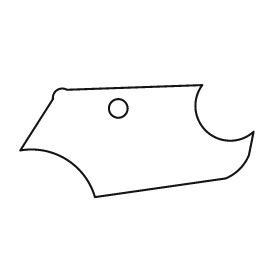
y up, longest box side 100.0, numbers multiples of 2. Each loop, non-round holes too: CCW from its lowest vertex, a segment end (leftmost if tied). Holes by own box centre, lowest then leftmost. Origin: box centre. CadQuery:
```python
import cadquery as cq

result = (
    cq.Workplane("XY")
    .moveTo(-18.0, -24.0)
    .lineTo(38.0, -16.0)
    .threePointArc((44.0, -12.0), (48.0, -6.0))
    .lineTo(50.0, 4.0)
    .threePointArc((30.0, 4.0), (28.0, 24.0))
    .lineTo(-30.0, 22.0)
    .threePointArc((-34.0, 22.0), (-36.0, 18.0))
    .lineTo(-50.0, -4.0)
    .threePointArc((-30.0, -8.0), (-18.0, -24.0))
    .close()
    .moveTo(-8.0, 14.0)
    .circle(4.0)
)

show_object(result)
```